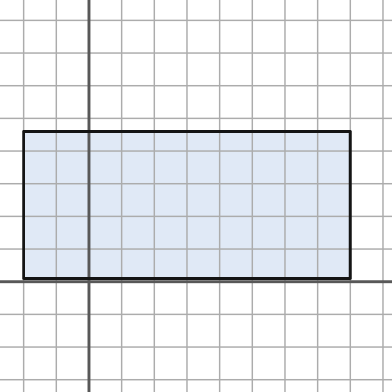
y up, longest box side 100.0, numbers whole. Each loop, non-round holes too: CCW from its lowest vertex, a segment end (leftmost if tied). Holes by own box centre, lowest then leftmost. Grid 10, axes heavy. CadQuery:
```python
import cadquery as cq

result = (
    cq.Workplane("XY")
    .moveTo(-20.0, 1.0)
    .lineTo(80.0, 1.0)
    .lineTo(80.0, 46.0)
    .lineTo(-20.0, 46.0)
    .close()
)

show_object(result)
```